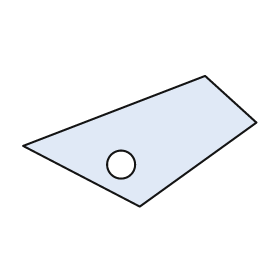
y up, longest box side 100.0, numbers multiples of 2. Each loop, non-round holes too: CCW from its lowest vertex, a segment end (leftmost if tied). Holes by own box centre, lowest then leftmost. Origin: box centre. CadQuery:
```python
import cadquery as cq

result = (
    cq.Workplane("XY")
    .moveTo(0.0, -28.0)
    .lineTo(50.0, 8.0)
    .lineTo(28.0, 28.0)
    .lineTo(-50.0, -2.0)
    .close()
    .moveTo(-8.0, -10.0)
    .circle(6.0)
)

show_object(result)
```